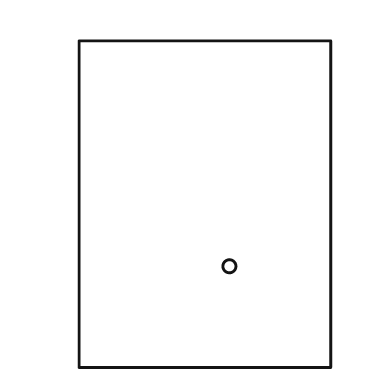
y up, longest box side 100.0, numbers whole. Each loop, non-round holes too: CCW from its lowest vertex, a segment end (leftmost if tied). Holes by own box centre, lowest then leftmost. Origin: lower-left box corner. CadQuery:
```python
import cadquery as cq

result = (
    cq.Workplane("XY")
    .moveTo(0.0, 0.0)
    .lineTo(77.0, 0.0)
    .lineTo(77.0, 100.0)
    .lineTo(0.0, 100.0)
    .close()
    .moveTo(46.0, 31.0)
    .circle(2.0)
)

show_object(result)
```